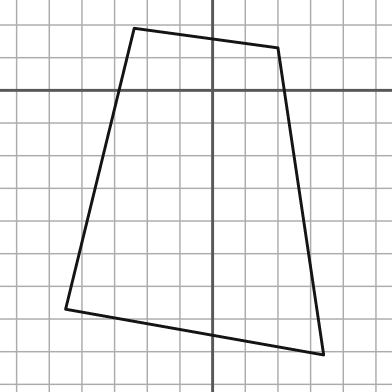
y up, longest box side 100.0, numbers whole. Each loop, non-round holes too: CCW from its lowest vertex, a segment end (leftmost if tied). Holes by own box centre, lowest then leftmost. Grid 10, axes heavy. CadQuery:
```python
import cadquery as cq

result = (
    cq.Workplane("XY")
    .moveTo(34.0, -81.0)
    .lineTo(20.0, 13.0)
    .lineTo(-24.0, 19.0)
    .lineTo(-45.0, -67.0)
    .close()
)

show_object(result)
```